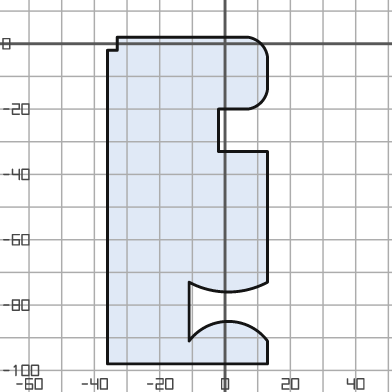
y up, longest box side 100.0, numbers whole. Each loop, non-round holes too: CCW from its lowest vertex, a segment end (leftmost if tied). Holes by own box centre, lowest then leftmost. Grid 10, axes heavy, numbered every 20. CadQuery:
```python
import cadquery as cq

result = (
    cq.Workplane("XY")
    .moveTo(-36.0, -98.0)
    .lineTo(13.0, -98.0)
    .lineTo(13.0, -91.0)
    .threePointArc((1.0, -85.0), (-11.0, -91.0))
    .lineTo(-11.0, -73.0)
    .threePointArc((1.0, -76.0), (13.0, -73.0))
    .lineTo(13.0, -33.0)
    .lineTo(-2.0, -33.0)
    .lineTo(-2.0, -20.0)
    .lineTo(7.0, -20.0)
    .threePointArc((11.0, -18.0), (13.0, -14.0))
    .lineTo(13.0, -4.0)
    .threePointArc((11.0, 0.0), (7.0, 2.0))
    .lineTo(-33.0, 2.0)
    .lineTo(-33.0, -2.0)
    .lineTo(-36.0, -2.0)
    .close()
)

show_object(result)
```